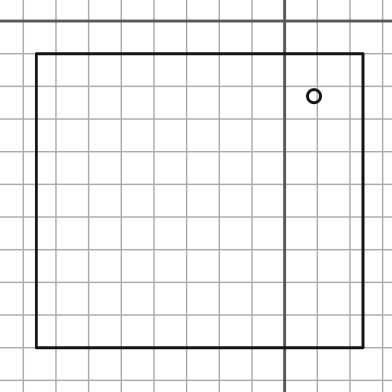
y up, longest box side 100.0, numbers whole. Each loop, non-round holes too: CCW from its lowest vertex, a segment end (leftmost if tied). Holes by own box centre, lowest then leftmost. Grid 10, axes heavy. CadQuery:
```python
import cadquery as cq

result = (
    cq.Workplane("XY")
    .moveTo(-76.0, -100.0)
    .lineTo(24.0, -100.0)
    .lineTo(24.0, -10.0)
    .lineTo(-76.0, -10.0)
    .close()
    .moveTo(9.0, -23.0)
    .circle(2.0)
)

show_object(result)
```